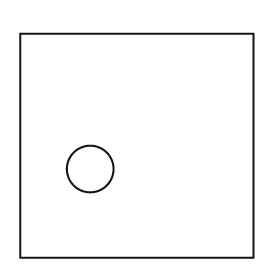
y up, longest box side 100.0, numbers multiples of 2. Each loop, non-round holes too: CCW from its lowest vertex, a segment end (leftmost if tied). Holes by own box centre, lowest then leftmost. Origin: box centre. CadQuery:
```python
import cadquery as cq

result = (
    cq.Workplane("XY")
    .moveTo(-50.0, -48.0)
    .lineTo(50.0, -48.0)
    .lineTo(50.0, 48.0)
    .lineTo(-50.0, 48.0)
    .close()
    .moveTo(-20.0, -10.0)
    .circle(10.0)
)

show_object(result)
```